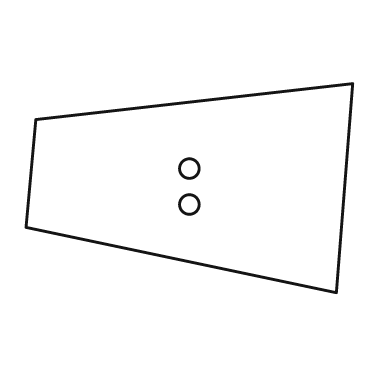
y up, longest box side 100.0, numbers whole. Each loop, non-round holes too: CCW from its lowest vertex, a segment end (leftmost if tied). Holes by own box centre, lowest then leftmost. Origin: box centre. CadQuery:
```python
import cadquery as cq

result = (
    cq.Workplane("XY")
    .moveTo(45.0, -32.0)
    .lineTo(50.0, 32.0)
    .lineTo(-47.0, 21.0)
    .lineTo(-50.0, -12.0)
    .close()
    .moveTo(0.0, -5.0)
    .circle(3.0)
    .moveTo(0.0, 6.0)
    .circle(3.0)
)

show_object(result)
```